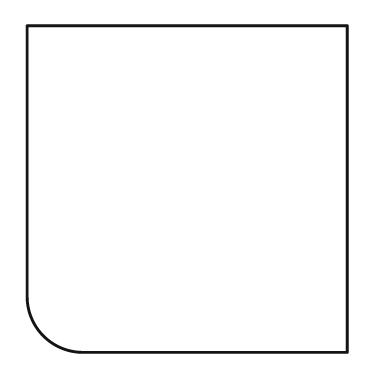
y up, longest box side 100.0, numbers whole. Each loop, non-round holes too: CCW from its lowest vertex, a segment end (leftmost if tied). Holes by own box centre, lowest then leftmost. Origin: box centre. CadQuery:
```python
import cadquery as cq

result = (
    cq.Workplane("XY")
    .moveTo(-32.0, -50.0)
    .lineTo(49.0, -50.0)
    .lineTo(49.0, 50.0)
    .lineTo(-49.0, 50.0)
    .lineTo(-49.0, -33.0)
    .threePointArc((-44.0, -45.0), (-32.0, -50.0))
    .close()
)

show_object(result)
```